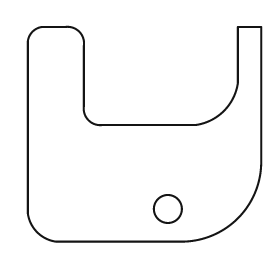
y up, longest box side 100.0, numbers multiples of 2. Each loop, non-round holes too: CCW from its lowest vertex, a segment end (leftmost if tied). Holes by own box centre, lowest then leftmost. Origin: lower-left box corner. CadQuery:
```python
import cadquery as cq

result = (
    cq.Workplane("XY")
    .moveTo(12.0, 0.0)
    .lineTo(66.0, 0.0)
    .threePointArc((90.0, 10.0), (100.0, 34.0))
    .lineTo(100.0, 92.0)
    .lineTo(90.0, 92.0)
    .lineTo(90.0, 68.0)
    .threePointArc((84.0, 56.0), (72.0, 50.0))
    .lineTo(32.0, 50.0)
    .threePointArc((26.0, 52.0), (24.0, 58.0))
    .lineTo(24.0, 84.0)
    .threePointArc((22.0, 90.0), (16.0, 92.0))
    .lineTo(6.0, 92.0)
    .threePointArc((2.0, 90.0), (0.0, 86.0))
    .lineTo(0.0, 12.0)
    .threePointArc((4.0, 4.0), (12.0, 0.0))
    .close()
    .moveTo(60.0, 14.0)
    .circle(6.0)
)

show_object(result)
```